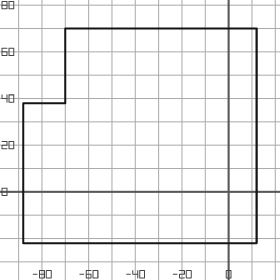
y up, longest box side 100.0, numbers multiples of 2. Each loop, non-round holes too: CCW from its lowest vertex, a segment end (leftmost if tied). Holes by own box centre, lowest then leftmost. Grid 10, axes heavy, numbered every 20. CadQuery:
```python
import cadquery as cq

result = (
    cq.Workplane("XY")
    .moveTo(-88.0, -22.0)
    .lineTo(12.0, -22.0)
    .lineTo(12.0, 70.0)
    .lineTo(-70.0, 70.0)
    .lineTo(-70.0, 38.0)
    .lineTo(-88.0, 38.0)
    .close()
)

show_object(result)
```